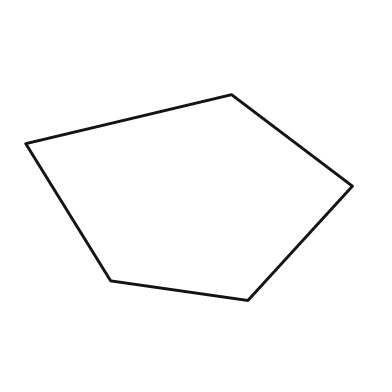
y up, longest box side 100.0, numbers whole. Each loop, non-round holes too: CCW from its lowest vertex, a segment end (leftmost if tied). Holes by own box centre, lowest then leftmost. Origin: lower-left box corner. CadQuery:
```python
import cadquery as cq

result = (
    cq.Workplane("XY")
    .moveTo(68.0, 0.0)
    .lineTo(100.0, 35.0)
    .lineTo(63.0, 63.0)
    .lineTo(0.0, 48.0)
    .lineTo(26.0, 6.0)
    .close()
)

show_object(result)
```